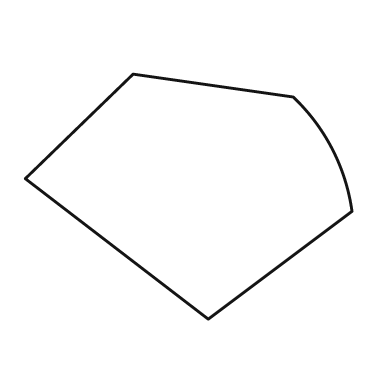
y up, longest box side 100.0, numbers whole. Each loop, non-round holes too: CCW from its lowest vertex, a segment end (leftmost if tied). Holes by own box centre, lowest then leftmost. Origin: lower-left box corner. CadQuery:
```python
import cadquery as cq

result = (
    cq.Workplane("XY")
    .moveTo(56.0, 0.0)
    .lineTo(100.0, 33.0)
    .threePointArc((94.0, 52.0), (82.0, 68.0))
    .lineTo(33.0, 75.0)
    .lineTo(0.0, 43.0)
    .close()
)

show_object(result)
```